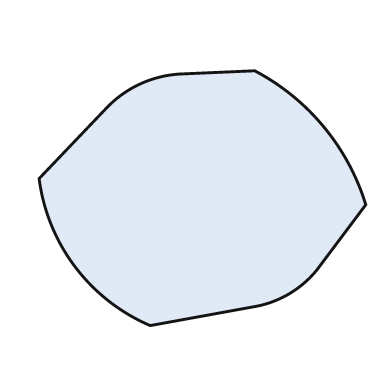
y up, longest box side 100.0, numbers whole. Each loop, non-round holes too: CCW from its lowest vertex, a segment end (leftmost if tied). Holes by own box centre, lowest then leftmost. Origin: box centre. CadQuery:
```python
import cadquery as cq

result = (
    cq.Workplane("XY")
    .moveTo(-16.0, -39.0)
    .lineTo(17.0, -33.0)
    .threePointArc((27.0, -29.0), (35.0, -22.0))
    .lineTo(50.0, -2.0)
    .threePointArc((37.0, 22.0), (16.0, 39.0))
    .lineTo(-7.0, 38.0)
    .threePointArc((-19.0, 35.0), (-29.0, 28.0))
    .lineTo(-50.0, 6.0)
    .threePointArc((-39.0, -21.0), (-16.0, -39.0))
    .close()
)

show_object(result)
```